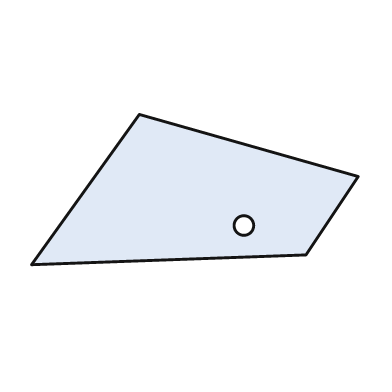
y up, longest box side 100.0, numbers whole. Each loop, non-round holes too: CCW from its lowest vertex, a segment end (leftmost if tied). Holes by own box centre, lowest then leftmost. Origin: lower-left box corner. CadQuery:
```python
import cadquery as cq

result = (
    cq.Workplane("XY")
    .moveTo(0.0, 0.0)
    .lineTo(84.0, 3.0)
    .lineTo(100.0, 27.0)
    .lineTo(33.0, 46.0)
    .close()
    .moveTo(65.0, 12.0)
    .circle(3.0)
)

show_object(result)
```